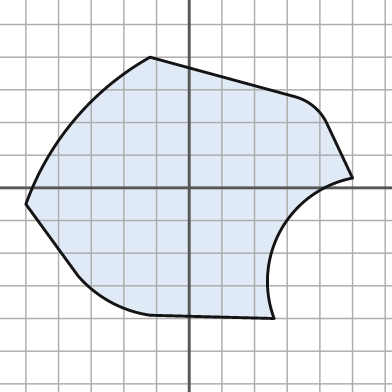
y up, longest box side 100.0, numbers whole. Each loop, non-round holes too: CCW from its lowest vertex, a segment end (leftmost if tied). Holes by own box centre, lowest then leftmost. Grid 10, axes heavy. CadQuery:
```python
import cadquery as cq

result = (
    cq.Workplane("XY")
    .moveTo(26.0, -40.0)
    .threePointArc((28.0, -13.0), (50.0, 3.0))
    .lineTo(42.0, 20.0)
    .threePointArc((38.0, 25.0), (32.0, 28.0))
    .lineTo(-12.0, 40.0)
    .threePointArc((-35.0, 21.0), (-50.0, -5.0))
    .lineTo(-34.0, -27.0)
    .threePointArc((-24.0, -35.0), (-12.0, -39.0))
    .close()
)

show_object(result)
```